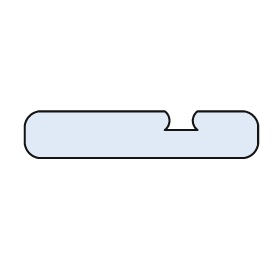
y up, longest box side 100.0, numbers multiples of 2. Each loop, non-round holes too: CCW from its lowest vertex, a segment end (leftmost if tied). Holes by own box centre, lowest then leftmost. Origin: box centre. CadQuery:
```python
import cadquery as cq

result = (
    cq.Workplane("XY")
    .moveTo(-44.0, -10.0)
    .lineTo(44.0, -10.0)
    .threePointArc((48.0, -8.0), (50.0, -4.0))
    .lineTo(50.0, 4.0)
    .threePointArc((48.0, 8.0), (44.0, 10.0))
    .lineTo(24.0, 10.0)
    .threePointArc((22.0, 6.0), (24.0, 2.0))
    .lineTo(10.0, 2.0)
    .threePointArc((12.0, 6.0), (10.0, 10.0))
    .lineTo(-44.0, 10.0)
    .threePointArc((-48.0, 8.0), (-50.0, 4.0))
    .lineTo(-50.0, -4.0)
    .threePointArc((-48.0, -8.0), (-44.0, -10.0))
    .close()
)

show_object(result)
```